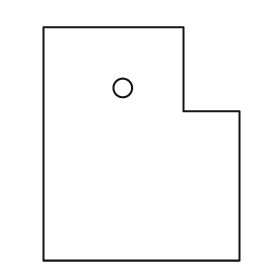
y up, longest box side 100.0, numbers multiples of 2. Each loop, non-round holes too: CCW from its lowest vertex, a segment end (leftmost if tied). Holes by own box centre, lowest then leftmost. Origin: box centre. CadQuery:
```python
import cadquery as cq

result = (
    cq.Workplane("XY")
    .moveTo(-42.0, -50.0)
    .lineTo(42.0, -50.0)
    .lineTo(42.0, 14.0)
    .lineTo(18.0, 14.0)
    .lineTo(18.0, 50.0)
    .lineTo(-42.0, 50.0)
    .close()
    .moveTo(-8.0, 24.0)
    .circle(4.0)
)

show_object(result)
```